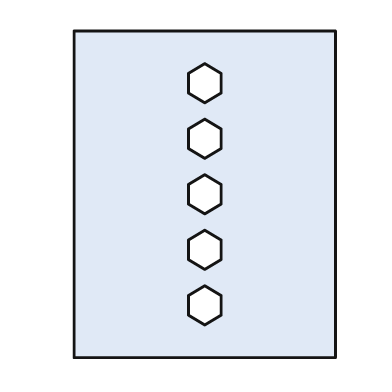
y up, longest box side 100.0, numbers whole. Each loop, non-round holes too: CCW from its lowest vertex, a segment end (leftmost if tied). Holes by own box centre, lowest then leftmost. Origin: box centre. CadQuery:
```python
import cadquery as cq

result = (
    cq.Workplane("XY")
    .moveTo(-40.0, -50.0)
    .lineTo(40.0, -50.0)
    .lineTo(40.0, 50.0)
    .lineTo(-40.0, 50.0)
    .close()
    .moveTo(0.0, -40.0)
    .lineTo(5.0, -37.0)
    .lineTo(5.0, -31.0)
    .lineTo(0.0, -28.0)
    .lineTo(-5.0, -31.0)
    .lineTo(-5.0, -37.0)
    .close()
    .moveTo(0.0, -23.0)
    .lineTo(5.0, -20.0)
    .lineTo(5.0, -14.0)
    .lineTo(0.0, -11.0)
    .lineTo(-5.0, -14.0)
    .lineTo(-5.0, -20.0)
    .close()
    .moveTo(0.0, -6.0)
    .lineTo(5.0, -3.0)
    .lineTo(5.0, 3.0)
    .lineTo(0.0, 6.0)
    .lineTo(-5.0, 3.0)
    .lineTo(-5.0, -3.0)
    .close()
    .moveTo(0.0, 11.0)
    .lineTo(5.0, 14.0)
    .lineTo(5.0, 20.0)
    .lineTo(0.0, 23.0)
    .lineTo(-5.0, 20.0)
    .lineTo(-5.0, 14.0)
    .close()
    .moveTo(0.0, 28.0)
    .lineTo(5.0, 31.0)
    .lineTo(5.0, 37.0)
    .lineTo(0.0, 40.0)
    .lineTo(-5.0, 37.0)
    .lineTo(-5.0, 31.0)
    .close()
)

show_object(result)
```